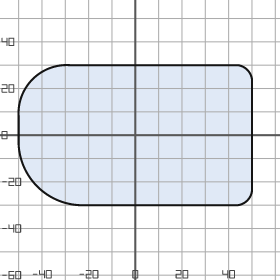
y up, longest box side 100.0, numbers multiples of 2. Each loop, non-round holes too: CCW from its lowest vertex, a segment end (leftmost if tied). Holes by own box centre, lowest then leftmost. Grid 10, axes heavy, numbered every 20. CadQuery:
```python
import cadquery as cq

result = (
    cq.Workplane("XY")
    .moveTo(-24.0, -30.0)
    .lineTo(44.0, -30.0)
    .threePointArc((48.0, -28.0), (50.0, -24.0))
    .lineTo(50.0, 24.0)
    .threePointArc((48.0, 28.0), (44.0, 30.0))
    .lineTo(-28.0, 30.0)
    .threePointArc((-44.0, 24.0), (-50.0, 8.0))
    .lineTo(-50.0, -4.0)
    .threePointArc((-42.0, -22.0), (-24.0, -30.0))
    .close()
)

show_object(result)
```